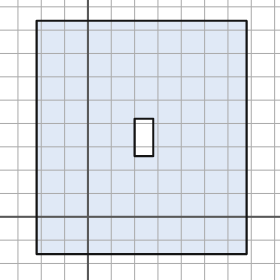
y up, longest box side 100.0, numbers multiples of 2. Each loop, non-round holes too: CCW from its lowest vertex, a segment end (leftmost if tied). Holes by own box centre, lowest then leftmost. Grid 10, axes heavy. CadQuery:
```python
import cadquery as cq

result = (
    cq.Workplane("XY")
    .moveTo(-22.0, -16.0)
    .lineTo(68.0, -16.0)
    .lineTo(68.0, 84.0)
    .lineTo(-22.0, 84.0)
    .close()
    .moveTo(20.0, 26.0)
    .lineTo(28.0, 26.0)
    .lineTo(28.0, 42.0)
    .lineTo(20.0, 42.0)
    .close()
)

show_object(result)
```